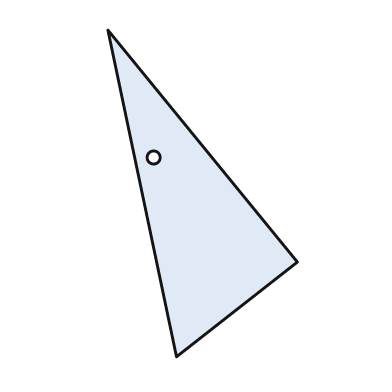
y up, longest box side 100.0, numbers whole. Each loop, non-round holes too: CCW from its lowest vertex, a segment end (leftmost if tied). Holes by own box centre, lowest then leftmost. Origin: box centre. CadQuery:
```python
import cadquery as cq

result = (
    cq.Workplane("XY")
    .moveTo(-8.0, -50.0)
    .lineTo(29.0, -21.0)
    .lineTo(-29.0, 50.0)
    .close()
    .moveTo(-15.0, 11.0)
    .circle(2.0)
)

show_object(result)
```